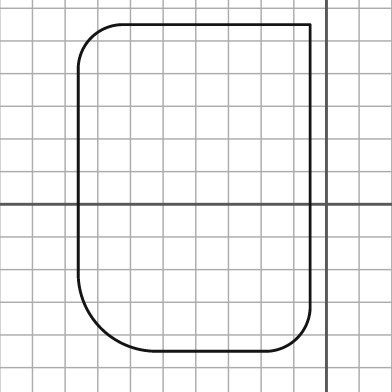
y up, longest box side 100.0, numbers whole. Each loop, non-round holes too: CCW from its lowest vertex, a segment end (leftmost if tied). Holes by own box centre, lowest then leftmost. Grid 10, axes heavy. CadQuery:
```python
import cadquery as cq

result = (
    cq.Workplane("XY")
    .moveTo(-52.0, -45.0)
    .lineTo(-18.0, -45.0)
    .threePointArc((-9.0, -41.0), (-5.0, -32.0))
    .lineTo(-5.0, 55.0)
    .lineTo(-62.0, 55.0)
    .threePointArc((-72.0, 51.0), (-76.0, 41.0))
    .lineTo(-76.0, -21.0)
    .threePointArc((-69.0, -38.0), (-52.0, -45.0))
    .close()
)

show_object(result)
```